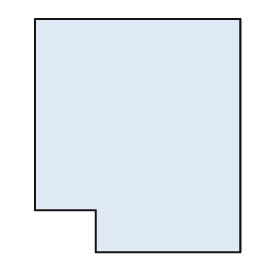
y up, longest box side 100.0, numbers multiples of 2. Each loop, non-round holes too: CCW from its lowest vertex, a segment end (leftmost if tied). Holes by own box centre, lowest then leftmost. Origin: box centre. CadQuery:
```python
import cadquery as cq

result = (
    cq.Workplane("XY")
    .moveTo(-18.0, -50.0)
    .lineTo(44.0, -50.0)
    .lineTo(44.0, 50.0)
    .lineTo(-44.0, 50.0)
    .lineTo(-44.0, -32.0)
    .lineTo(-18.0, -32.0)
    .close()
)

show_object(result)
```